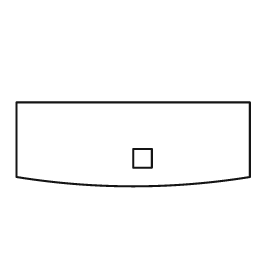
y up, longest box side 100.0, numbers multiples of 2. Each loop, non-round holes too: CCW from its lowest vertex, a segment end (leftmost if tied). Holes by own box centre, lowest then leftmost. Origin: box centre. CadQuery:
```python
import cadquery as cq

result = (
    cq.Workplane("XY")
    .moveTo(-50.0, -14.0)
    .threePointArc((0.0, -18.0), (50.0, -14.0))
    .lineTo(50.0, 18.0)
    .lineTo(-50.0, 18.0)
    .close()
    .moveTo(0.0, -10.0)
    .lineTo(8.0, -10.0)
    .lineTo(8.0, -2.0)
    .lineTo(0.0, -2.0)
    .close()
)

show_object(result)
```